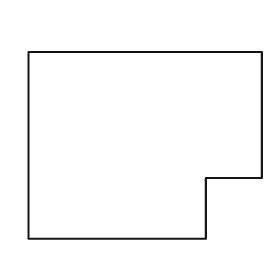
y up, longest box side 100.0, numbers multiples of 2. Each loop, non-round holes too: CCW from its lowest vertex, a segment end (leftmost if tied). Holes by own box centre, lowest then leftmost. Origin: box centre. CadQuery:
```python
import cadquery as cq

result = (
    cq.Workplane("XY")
    .moveTo(-50.0, -40.0)
    .lineTo(26.0, -40.0)
    .lineTo(26.0, -14.0)
    .lineTo(50.0, -14.0)
    .lineTo(50.0, 40.0)
    .lineTo(-50.0, 40.0)
    .close()
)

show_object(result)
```